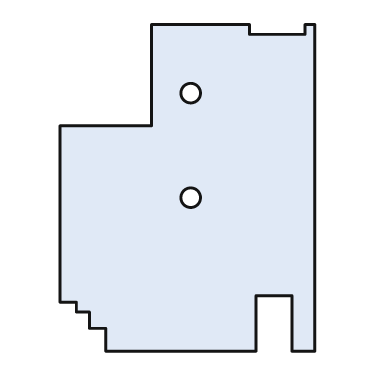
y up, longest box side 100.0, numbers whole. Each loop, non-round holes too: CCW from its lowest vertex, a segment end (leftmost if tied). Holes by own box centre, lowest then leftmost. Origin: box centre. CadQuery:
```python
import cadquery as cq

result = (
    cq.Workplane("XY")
    .moveTo(-25.0, -50.0)
    .lineTo(21.0, -50.0)
    .lineTo(21.0, -33.0)
    .lineTo(32.0, -33.0)
    .lineTo(32.0, -50.0)
    .lineTo(39.0, -50.0)
    .lineTo(39.0, 50.0)
    .lineTo(36.0, 50.0)
    .lineTo(36.0, 47.0)
    .lineTo(19.0, 47.0)
    .lineTo(19.0, 50.0)
    .lineTo(-11.0, 50.0)
    .lineTo(-11.0, 19.0)
    .lineTo(-39.0, 19.0)
    .lineTo(-39.0, -35.0)
    .lineTo(-34.0, -35.0)
    .lineTo(-34.0, -38.0)
    .lineTo(-30.0, -38.0)
    .lineTo(-30.0, -43.0)
    .lineTo(-25.0, -43.0)
    .close()
    .moveTo(1.0, -3.0)
    .circle(3.0)
    .moveTo(1.0, 29.0)
    .circle(3.0)
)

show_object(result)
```